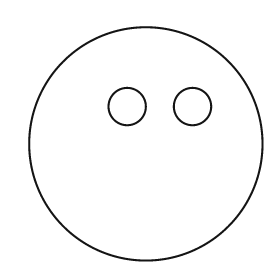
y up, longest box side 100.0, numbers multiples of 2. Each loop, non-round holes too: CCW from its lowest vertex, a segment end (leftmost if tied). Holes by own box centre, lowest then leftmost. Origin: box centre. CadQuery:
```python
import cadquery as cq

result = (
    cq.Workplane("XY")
    .moveTo(0.0, 0.0)
    .circle(50.0)
    .moveTo(-8.0, 16.0)
    .circle(8.0)
    .moveTo(20.0, 16.0)
    .circle(8.0)
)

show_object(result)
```